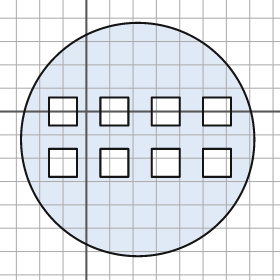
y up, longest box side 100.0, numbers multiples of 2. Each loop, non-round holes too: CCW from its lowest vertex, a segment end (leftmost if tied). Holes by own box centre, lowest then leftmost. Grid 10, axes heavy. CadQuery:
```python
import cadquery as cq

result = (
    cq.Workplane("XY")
    .moveTo(22.0, -12.0)
    .circle(50.0)
    .moveTo(-16.0, -28.0)
    .lineTo(-4.0, -28.0)
    .lineTo(-4.0, -16.0)
    .lineTo(-16.0, -16.0)
    .close()
    .moveTo(6.0, -28.0)
    .lineTo(18.0, -28.0)
    .lineTo(18.0, -16.0)
    .lineTo(6.0, -16.0)
    .close()
    .moveTo(28.0, -28.0)
    .lineTo(40.0, -28.0)
    .lineTo(40.0, -16.0)
    .lineTo(28.0, -16.0)
    .close()
    .moveTo(50.0, -28.0)
    .lineTo(62.0, -28.0)
    .lineTo(62.0, -16.0)
    .lineTo(50.0, -16.0)
    .close()
    .moveTo(-16.0, -6.0)
    .lineTo(-4.0, -6.0)
    .lineTo(-4.0, 6.0)
    .lineTo(-16.0, 6.0)
    .close()
    .moveTo(6.0, -6.0)
    .lineTo(18.0, -6.0)
    .lineTo(18.0, 6.0)
    .lineTo(6.0, 6.0)
    .close()
    .moveTo(28.0, -6.0)
    .lineTo(40.0, -6.0)
    .lineTo(40.0, 6.0)
    .lineTo(28.0, 6.0)
    .close()
    .moveTo(50.0, -6.0)
    .lineTo(62.0, -6.0)
    .lineTo(62.0, 6.0)
    .lineTo(50.0, 6.0)
    .close()
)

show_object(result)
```